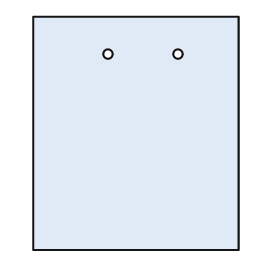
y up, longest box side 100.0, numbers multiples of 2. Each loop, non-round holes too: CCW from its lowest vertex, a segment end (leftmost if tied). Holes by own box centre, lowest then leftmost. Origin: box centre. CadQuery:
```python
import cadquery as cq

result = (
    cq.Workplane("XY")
    .moveTo(-44.0, -50.0)
    .lineTo(44.0, -50.0)
    .lineTo(44.0, 50.0)
    .lineTo(-44.0, 50.0)
    .close()
    .moveTo(-12.0, 34.0)
    .circle(2.0)
    .moveTo(18.0, 34.0)
    .circle(2.0)
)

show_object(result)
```